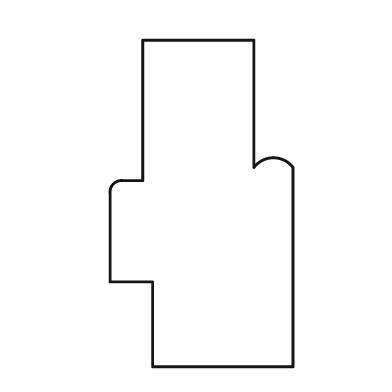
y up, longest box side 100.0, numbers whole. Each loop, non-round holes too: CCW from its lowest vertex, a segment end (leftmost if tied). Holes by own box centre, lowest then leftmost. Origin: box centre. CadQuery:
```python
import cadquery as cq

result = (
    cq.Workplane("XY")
    .moveTo(-15.0, -50.0)
    .lineTo(28.0, -50.0)
    .lineTo(28.0, 11.0)
    .threePointArc((22.0, 14.0), (16.0, 11.0))
    .lineTo(16.0, 50.0)
    .lineTo(-18.0, 50.0)
    .lineTo(-18.0, 7.0)
    .lineTo(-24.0, 7.0)
    .threePointArc((-27.0, 6.0), (-28.0, 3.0))
    .lineTo(-28.0, -24.0)
    .lineTo(-15.0, -24.0)
    .close()
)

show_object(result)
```